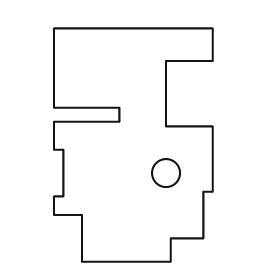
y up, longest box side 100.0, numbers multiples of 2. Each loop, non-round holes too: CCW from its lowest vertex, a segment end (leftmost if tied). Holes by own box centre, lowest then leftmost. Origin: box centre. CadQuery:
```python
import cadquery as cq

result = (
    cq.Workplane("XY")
    .moveTo(-22.0, -50.0)
    .lineTo(16.0, -50.0)
    .lineTo(16.0, -40.0)
    .lineTo(30.0, -40.0)
    .lineTo(30.0, -20.0)
    .lineTo(34.0, -20.0)
    .lineTo(34.0, 8.0)
    .lineTo(14.0, 8.0)
    .lineTo(14.0, 36.0)
    .lineTo(34.0, 36.0)
    .lineTo(34.0, 50.0)
    .lineTo(-34.0, 50.0)
    .lineTo(-34.0, 16.0)
    .lineTo(-6.0, 16.0)
    .lineTo(-6.0, 10.0)
    .lineTo(-34.0, 10.0)
    .lineTo(-34.0, -2.0)
    .lineTo(-30.0, -2.0)
    .lineTo(-30.0, -22.0)
    .lineTo(-34.0, -22.0)
    .lineTo(-34.0, -30.0)
    .lineTo(-22.0, -30.0)
    .close()
    .moveTo(14.0, -12.0)
    .circle(6.0)
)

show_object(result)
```